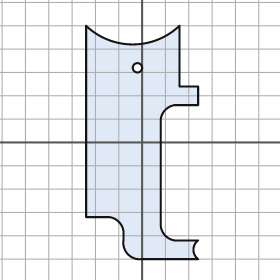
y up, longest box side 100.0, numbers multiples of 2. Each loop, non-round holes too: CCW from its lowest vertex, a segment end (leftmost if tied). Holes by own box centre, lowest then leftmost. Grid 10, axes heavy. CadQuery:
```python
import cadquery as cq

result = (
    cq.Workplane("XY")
    .moveTo(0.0, -50.0)
    .lineTo(24.0, -50.0)
    .threePointArc((22.0, -46.0), (24.0, -42.0))
    .lineTo(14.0, -42.0)
    .threePointArc((10.0, -40.0), (8.0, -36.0))
    .lineTo(8.0, 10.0)
    .threePointArc((10.0, 14.0), (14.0, 16.0))
    .lineTo(24.0, 16.0)
    .lineTo(24.0, 24.0)
    .lineTo(16.0, 24.0)
    .lineTo(16.0, 50.0)
    .threePointArc((-4.0, 42.0), (-24.0, 50.0))
    .lineTo(-24.0, -32.0)
    .lineTo(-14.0, -32.0)
    .threePointArc((-10.0, -34.0), (-8.0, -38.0))
    .lineTo(-8.0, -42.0)
    .threePointArc((-6.0, -48.0), (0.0, -50.0))
    .close()
    .moveTo(-2.0, 32.0)
    .circle(2.0)
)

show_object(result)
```